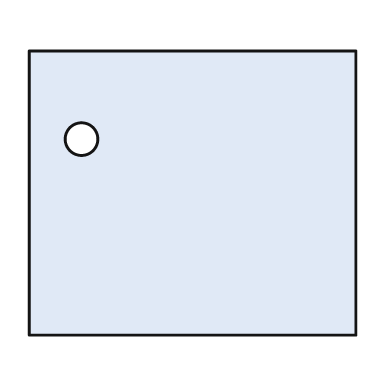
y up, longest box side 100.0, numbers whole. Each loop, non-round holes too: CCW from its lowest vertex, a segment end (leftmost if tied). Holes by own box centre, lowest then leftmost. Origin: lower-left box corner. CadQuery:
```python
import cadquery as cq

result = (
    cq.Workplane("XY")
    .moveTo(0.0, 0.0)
    .lineTo(100.0, 0.0)
    .lineTo(100.0, 87.0)
    .lineTo(0.0, 87.0)
    .close()
    .moveTo(16.0, 60.0)
    .circle(5.0)
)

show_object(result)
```